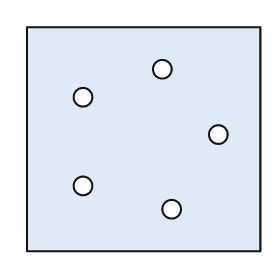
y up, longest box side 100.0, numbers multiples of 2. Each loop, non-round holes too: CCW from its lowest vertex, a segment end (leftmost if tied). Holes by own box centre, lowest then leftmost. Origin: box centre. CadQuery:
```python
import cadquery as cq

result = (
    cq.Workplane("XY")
    .moveTo(-50.0, -48.0)
    .lineTo(50.0, -48.0)
    .lineTo(50.0, 48.0)
    .lineTo(-50.0, 48.0)
    .close()
    .moveTo(12.0, -30.0)
    .circle(4.0)
    .moveTo(-26.0, -20.0)
    .circle(4.0)
    .moveTo(32.0, 2.0)
    .circle(4.0)
    .moveTo(-26.0, 18.0)
    .circle(4.0)
    .moveTo(8.0, 30.0)
    .circle(4.0)
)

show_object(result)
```